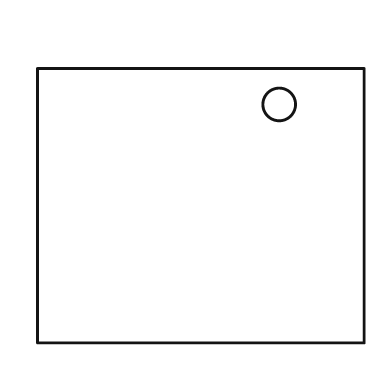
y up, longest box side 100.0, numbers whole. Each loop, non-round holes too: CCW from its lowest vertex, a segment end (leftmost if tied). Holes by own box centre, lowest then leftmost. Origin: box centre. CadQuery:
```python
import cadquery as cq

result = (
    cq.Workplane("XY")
    .moveTo(-50.0, -42.0)
    .lineTo(50.0, -42.0)
    .lineTo(50.0, 42.0)
    .lineTo(-50.0, 42.0)
    .close()
    .moveTo(24.0, 31.0)
    .circle(5.0)
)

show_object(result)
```